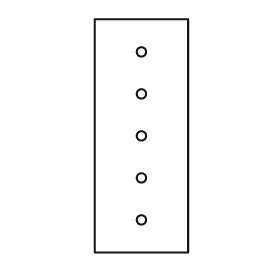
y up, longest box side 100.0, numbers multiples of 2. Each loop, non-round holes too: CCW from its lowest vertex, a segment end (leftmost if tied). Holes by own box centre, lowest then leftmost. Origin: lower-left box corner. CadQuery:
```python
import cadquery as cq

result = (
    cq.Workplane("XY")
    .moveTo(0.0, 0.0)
    .lineTo(40.0, 0.0)
    .lineTo(40.0, 100.0)
    .lineTo(0.0, 100.0)
    .close()
    .moveTo(20.0, 14.0)
    .circle(2.0)
    .moveTo(20.0, 32.0)
    .circle(2.0)
    .moveTo(20.0, 50.0)
    .circle(2.0)
    .moveTo(20.0, 68.0)
    .circle(2.0)
    .moveTo(20.0, 86.0)
    .circle(2.0)
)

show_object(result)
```